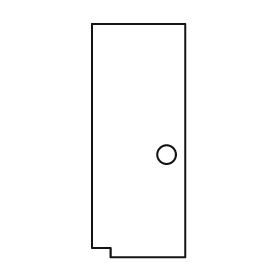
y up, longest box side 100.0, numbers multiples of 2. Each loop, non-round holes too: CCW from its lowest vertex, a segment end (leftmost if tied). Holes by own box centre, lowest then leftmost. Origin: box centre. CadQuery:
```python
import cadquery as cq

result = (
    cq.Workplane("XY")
    .moveTo(-12.0, -50.0)
    .lineTo(20.0, -50.0)
    .lineTo(20.0, 50.0)
    .lineTo(-20.0, 50.0)
    .lineTo(-20.0, -46.0)
    .lineTo(-12.0, -46.0)
    .close()
    .moveTo(12.0, -6.0)
    .circle(4.0)
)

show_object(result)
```